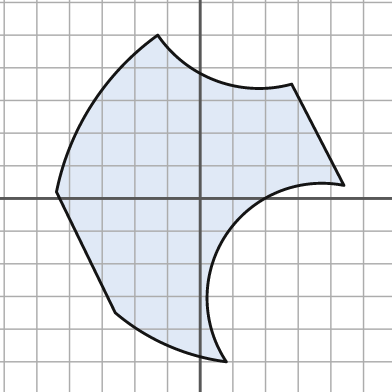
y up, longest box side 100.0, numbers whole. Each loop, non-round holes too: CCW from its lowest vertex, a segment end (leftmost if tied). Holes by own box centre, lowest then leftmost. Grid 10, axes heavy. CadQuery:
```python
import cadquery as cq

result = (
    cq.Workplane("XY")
    .moveTo(8.0, -50.0)
    .threePointArc((8.0, -11.0), (44.0, 4.0))
    .lineTo(28.0, 35.0)
    .threePointArc((5.0, 36.0), (-13.0, 50.0))
    .threePointArc((-33.0, 29.0), (-44.0, 2.0))
    .lineTo(-26.0, -35.0)
    .threePointArc((-10.0, -45.0), (8.0, -50.0))
    .close()
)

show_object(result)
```